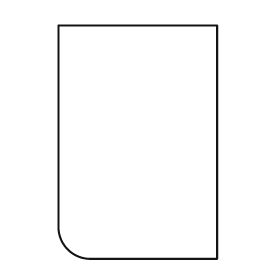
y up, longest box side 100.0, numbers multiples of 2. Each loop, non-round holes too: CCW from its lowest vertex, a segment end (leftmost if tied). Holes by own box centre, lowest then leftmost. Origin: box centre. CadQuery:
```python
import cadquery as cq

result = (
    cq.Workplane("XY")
    .moveTo(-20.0, -50.0)
    .lineTo(34.0, -50.0)
    .lineTo(34.0, 50.0)
    .lineTo(-34.0, 50.0)
    .lineTo(-34.0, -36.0)
    .threePointArc((-30.0, -46.0), (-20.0, -50.0))
    .close()
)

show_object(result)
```